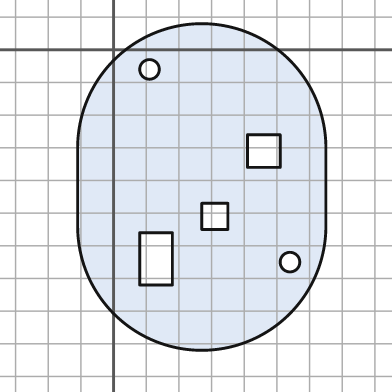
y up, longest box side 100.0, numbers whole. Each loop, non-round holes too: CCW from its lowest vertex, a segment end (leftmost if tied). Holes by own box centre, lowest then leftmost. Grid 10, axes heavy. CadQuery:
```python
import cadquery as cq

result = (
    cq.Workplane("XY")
    .moveTo(-11.0, -54.0)
    .threePointArc((27.0, -92.0), (65.0, -54.0))
    .lineTo(65.0, -30.0)
    .threePointArc((27.0, 8.0), (-11.0, -30.0))
    .close()
    .moveTo(54.0, -65.0)
    .circle(3.0)
    .moveTo(8.0, -72.0)
    .lineTo(18.0, -72.0)
    .lineTo(18.0, -56.0)
    .lineTo(8.0, -56.0)
    .close()
    .moveTo(27.0, -55.0)
    .lineTo(35.0, -55.0)
    .lineTo(35.0, -47.0)
    .lineTo(27.0, -47.0)
    .close()
    .moveTo(41.0, -36.0)
    .lineTo(51.0, -36.0)
    .lineTo(51.0, -26.0)
    .lineTo(41.0, -26.0)
    .close()
    .moveTo(11.0, -6.0)
    .circle(3.0)
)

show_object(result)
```